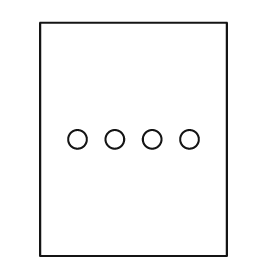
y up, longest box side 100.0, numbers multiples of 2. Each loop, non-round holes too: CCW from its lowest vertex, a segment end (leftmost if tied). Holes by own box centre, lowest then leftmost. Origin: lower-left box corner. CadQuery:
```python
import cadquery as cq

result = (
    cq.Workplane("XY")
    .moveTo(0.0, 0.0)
    .lineTo(80.0, 0.0)
    .lineTo(80.0, 100.0)
    .lineTo(0.0, 100.0)
    .close()
    .moveTo(16.0, 50.0)
    .circle(4.0)
    .moveTo(32.0, 50.0)
    .circle(4.0)
    .moveTo(48.0, 50.0)
    .circle(4.0)
    .moveTo(64.0, 50.0)
    .circle(4.0)
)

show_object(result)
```